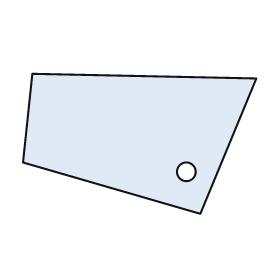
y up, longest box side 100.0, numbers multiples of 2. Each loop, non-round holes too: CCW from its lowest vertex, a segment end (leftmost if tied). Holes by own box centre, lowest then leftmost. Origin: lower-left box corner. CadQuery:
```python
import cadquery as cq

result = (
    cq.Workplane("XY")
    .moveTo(76.0, 0.0)
    .lineTo(100.0, 58.0)
    .lineTo(4.0, 60.0)
    .lineTo(0.0, 22.0)
    .close()
    .moveTo(70.0, 18.0)
    .circle(4.0)
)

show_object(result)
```